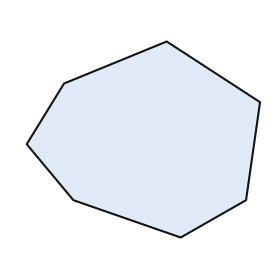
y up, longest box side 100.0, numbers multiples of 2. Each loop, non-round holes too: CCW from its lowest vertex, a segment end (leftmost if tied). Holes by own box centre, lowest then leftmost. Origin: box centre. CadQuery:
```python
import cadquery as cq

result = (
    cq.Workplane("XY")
    .moveTo(16.0, -42.0)
    .lineTo(44.0, -26.0)
    .lineTo(50.0, 16.0)
    .lineTo(10.0, 42.0)
    .lineTo(-34.0, 24.0)
    .lineTo(-50.0, -2.0)
    .lineTo(-30.0, -26.0)
    .close()
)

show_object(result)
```